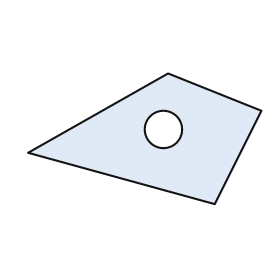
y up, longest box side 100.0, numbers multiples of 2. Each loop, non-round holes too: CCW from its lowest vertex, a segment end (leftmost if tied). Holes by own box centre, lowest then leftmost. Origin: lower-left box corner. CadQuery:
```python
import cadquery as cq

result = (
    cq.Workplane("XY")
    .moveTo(80.0, 0.0)
    .lineTo(100.0, 40.0)
    .lineTo(60.0, 56.0)
    .lineTo(0.0, 22.0)
    .close()
    .moveTo(58.0, 32.0)
    .circle(8.0)
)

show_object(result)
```